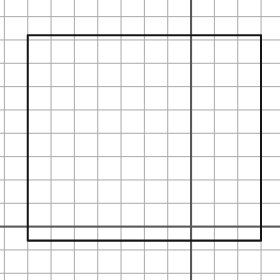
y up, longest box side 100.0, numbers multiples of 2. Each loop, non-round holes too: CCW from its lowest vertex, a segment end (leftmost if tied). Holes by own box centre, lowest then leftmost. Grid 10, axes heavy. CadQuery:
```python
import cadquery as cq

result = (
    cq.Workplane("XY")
    .moveTo(-70.0, -6.0)
    .lineTo(30.0, -6.0)
    .lineTo(30.0, 82.0)
    .lineTo(-70.0, 82.0)
    .close()
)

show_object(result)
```